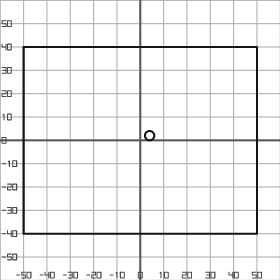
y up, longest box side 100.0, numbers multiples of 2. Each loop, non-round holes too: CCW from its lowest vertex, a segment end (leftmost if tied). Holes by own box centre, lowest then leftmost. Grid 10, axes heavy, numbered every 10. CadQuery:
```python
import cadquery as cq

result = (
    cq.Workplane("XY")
    .moveTo(-50.0, -40.0)
    .lineTo(50.0, -40.0)
    .lineTo(50.0, 40.0)
    .lineTo(-50.0, 40.0)
    .close()
    .moveTo(4.0, 2.0)
    .circle(2.0)
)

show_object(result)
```